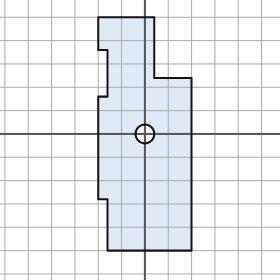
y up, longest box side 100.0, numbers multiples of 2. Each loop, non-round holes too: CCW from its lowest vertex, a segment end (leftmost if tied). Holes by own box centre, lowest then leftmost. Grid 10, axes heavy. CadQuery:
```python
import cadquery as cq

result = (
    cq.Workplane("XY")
    .moveTo(-16.0, -50.0)
    .lineTo(20.0, -50.0)
    .lineTo(20.0, 24.0)
    .lineTo(4.0, 24.0)
    .lineTo(4.0, 50.0)
    .lineTo(-20.0, 50.0)
    .lineTo(-20.0, 36.0)
    .lineTo(-16.0, 36.0)
    .lineTo(-16.0, 16.0)
    .lineTo(-20.0, 16.0)
    .lineTo(-20.0, -28.0)
    .lineTo(-16.0, -28.0)
    .close()
    .moveTo(0.0, 0.0)
    .circle(4.0)
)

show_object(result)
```